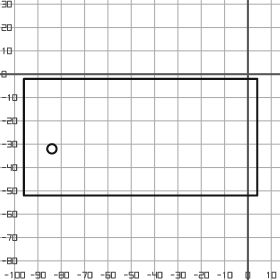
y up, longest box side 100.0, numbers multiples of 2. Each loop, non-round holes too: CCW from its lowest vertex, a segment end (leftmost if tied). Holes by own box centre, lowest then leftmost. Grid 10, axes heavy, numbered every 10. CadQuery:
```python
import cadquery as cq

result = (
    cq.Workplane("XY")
    .moveTo(-96.0, -52.0)
    .lineTo(4.0, -52.0)
    .lineTo(4.0, -2.0)
    .lineTo(-96.0, -2.0)
    .close()
    .moveTo(-84.0, -32.0)
    .circle(2.0)
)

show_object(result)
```